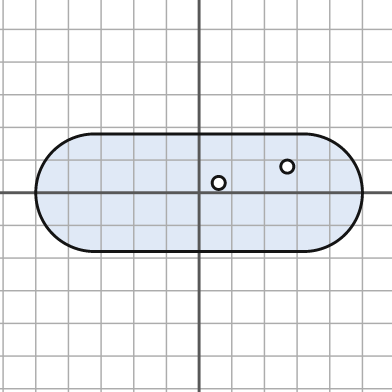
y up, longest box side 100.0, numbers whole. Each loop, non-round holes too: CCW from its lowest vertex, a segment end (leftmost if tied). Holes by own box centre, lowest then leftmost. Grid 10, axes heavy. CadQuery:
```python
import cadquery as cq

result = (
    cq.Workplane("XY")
    .moveTo(-32.0, -18.0)
    .lineTo(32.0, -18.0)
    .threePointArc((50.0, 0.0), (32.0, 18.0))
    .lineTo(-32.0, 18.0)
    .threePointArc((-50.0, 0.0), (-32.0, -18.0))
    .close()
    .moveTo(6.0, 3.0)
    .circle(2.0)
    .moveTo(27.0, 8.0)
    .circle(2.0)
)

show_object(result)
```